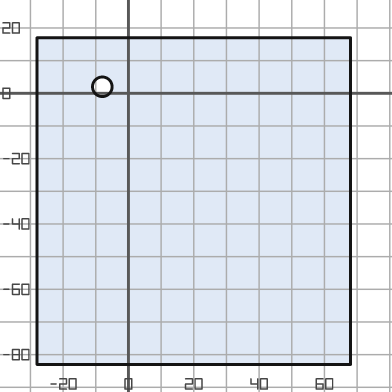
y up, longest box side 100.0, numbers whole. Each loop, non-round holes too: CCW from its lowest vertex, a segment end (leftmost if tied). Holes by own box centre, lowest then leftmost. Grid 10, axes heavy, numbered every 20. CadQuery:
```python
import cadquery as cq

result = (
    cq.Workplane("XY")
    .moveTo(-28.0, -83.0)
    .lineTo(68.0, -83.0)
    .lineTo(68.0, 17.0)
    .lineTo(-28.0, 17.0)
    .close()
    .moveTo(-8.0, 2.0)
    .circle(3.0)
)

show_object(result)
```